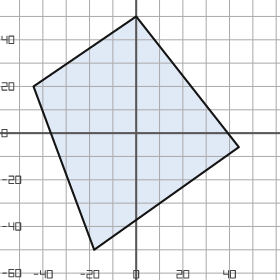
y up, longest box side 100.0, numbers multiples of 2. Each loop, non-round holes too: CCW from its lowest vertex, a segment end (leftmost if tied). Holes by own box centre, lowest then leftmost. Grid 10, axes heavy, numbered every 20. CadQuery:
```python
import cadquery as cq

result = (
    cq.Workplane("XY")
    .moveTo(-18.0, -50.0)
    .lineTo(44.0, -6.0)
    .lineTo(0.0, 50.0)
    .lineTo(-44.0, 20.0)
    .close()
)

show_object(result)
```